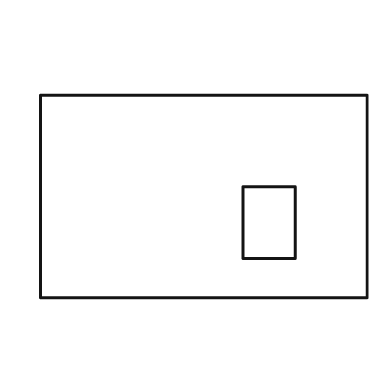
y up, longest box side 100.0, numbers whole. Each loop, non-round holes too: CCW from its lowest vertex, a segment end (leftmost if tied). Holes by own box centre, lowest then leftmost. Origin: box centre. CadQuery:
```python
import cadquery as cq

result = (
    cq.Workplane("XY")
    .moveTo(-50.0, -31.0)
    .lineTo(50.0, -31.0)
    .lineTo(50.0, 31.0)
    .lineTo(-50.0, 31.0)
    .close()
    .moveTo(12.0, -19.0)
    .lineTo(28.0, -19.0)
    .lineTo(28.0, 3.0)
    .lineTo(12.0, 3.0)
    .close()
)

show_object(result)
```